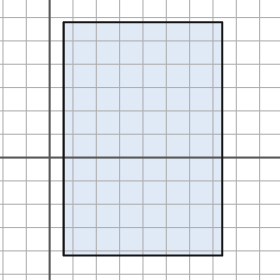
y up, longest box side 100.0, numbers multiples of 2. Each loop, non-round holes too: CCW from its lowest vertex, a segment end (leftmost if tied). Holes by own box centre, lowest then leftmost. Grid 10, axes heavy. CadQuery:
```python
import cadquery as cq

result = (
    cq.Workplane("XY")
    .moveTo(6.0, -42.0)
    .lineTo(74.0, -42.0)
    .lineTo(74.0, 58.0)
    .lineTo(6.0, 58.0)
    .close()
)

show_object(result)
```